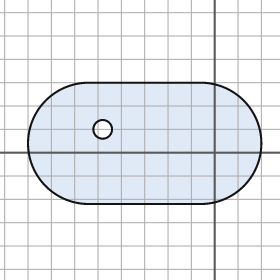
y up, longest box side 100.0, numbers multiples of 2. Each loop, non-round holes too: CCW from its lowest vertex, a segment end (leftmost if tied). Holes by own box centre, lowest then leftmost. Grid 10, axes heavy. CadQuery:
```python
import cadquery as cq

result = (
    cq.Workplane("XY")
    .moveTo(-54.0, -22.0)
    .lineTo(-6.0, -22.0)
    .threePointArc((20.0, 4.0), (-6.0, 30.0))
    .lineTo(-54.0, 30.0)
    .threePointArc((-80.0, 4.0), (-54.0, -22.0))
    .close()
    .moveTo(-48.0, 10.0)
    .circle(4.0)
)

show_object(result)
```